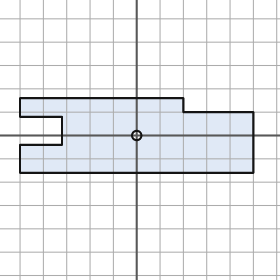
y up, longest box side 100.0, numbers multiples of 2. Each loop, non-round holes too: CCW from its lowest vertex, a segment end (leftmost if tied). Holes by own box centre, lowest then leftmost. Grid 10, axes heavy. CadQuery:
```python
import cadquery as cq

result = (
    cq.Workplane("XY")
    .moveTo(-50.0, -16.0)
    .lineTo(50.0, -16.0)
    .lineTo(50.0, 10.0)
    .lineTo(20.0, 10.0)
    .lineTo(20.0, 16.0)
    .lineTo(-50.0, 16.0)
    .lineTo(-50.0, 8.0)
    .lineTo(-32.0, 8.0)
    .lineTo(-32.0, -4.0)
    .lineTo(-50.0, -4.0)
    .close()
    .moveTo(0.0, 0.0)
    .circle(2.0)
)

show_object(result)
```